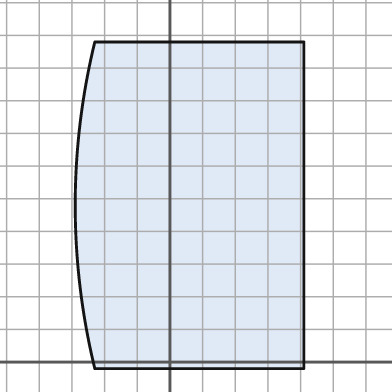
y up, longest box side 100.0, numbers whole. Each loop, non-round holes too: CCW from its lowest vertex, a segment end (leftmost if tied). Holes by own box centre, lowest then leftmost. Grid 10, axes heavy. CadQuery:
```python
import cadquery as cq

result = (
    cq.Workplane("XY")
    .moveTo(-23.0, -2.0)
    .lineTo(41.0, -2.0)
    .lineTo(41.0, 98.0)
    .lineTo(-23.0, 98.0)
    .threePointArc((-29.0, 48.0), (-23.0, -2.0))
    .close()
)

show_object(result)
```